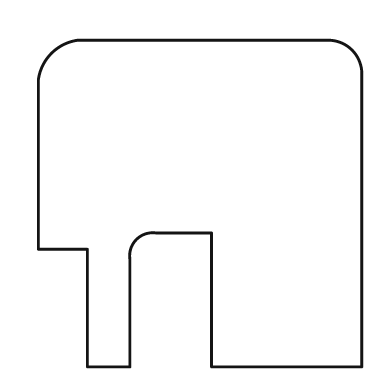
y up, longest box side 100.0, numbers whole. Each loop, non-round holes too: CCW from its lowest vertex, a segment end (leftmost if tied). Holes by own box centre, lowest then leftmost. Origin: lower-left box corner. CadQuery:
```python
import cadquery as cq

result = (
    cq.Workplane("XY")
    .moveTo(15.0, 0.0)
    .lineTo(28.0, 0.0)
    .lineTo(28.0, 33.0)
    .threePointArc((30.0, 39.0), (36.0, 41.0))
    .lineTo(53.0, 41.0)
    .lineTo(53.0, 0.0)
    .lineTo(99.0, 0.0)
    .lineTo(99.0, 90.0)
    .threePointArc((96.0, 97.0), (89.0, 100.0))
    .lineTo(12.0, 100.0)
    .threePointArc((4.0, 96.0), (0.0, 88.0))
    .lineTo(0.0, 36.0)
    .lineTo(15.0, 36.0)
    .close()
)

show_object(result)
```